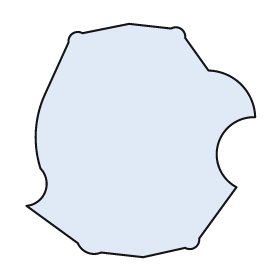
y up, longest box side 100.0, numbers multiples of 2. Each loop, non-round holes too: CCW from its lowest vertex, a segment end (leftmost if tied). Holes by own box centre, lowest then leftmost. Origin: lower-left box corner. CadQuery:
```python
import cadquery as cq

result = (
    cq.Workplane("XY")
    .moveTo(50.0, 0.0)
    .lineTo(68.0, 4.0)
    .threePointArc((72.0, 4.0), (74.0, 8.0))
    .lineTo(90.0, 30.0)
    .threePointArc((82.0, 48.0), (98.0, 60.0))
    .threePointArc((92.0, 74.0), (78.0, 80.0))
    .lineTo(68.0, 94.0)
    .threePointArc((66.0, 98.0), (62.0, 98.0))
    .lineTo(44.0, 100.0)
    .lineTo(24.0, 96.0)
    .threePointArc((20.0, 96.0), (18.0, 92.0))
    .lineTo(8.0, 70.0)
    .threePointArc((4.0, 54.0), (6.0, 38.0))
    .threePointArc((8.0, 28.0), (0.0, 22.0))
    .lineTo(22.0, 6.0)
    .threePointArc((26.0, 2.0), (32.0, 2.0))
    .close()
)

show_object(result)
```